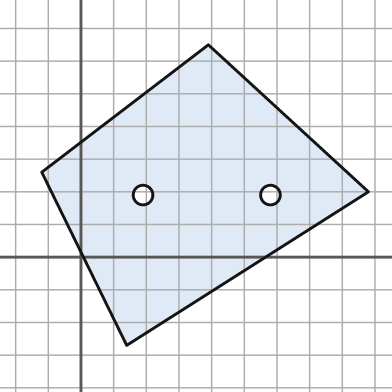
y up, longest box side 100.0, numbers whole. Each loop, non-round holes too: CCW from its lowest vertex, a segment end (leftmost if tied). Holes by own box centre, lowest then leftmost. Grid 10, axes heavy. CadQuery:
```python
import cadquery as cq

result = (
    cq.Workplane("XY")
    .moveTo(14.0, -27.0)
    .lineTo(88.0, 20.0)
    .lineTo(39.0, 65.0)
    .lineTo(-12.0, 26.0)
    .close()
    .moveTo(19.0, 19.0)
    .circle(3.0)
    .moveTo(58.0, 19.0)
    .circle(3.0)
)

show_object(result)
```